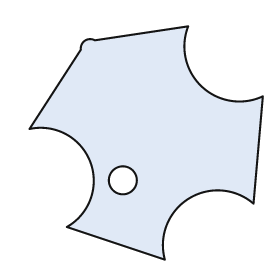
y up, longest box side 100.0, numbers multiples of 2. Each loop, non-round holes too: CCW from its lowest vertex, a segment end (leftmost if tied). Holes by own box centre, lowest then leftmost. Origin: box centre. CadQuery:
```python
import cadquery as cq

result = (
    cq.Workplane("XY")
    .moveTo(8.0, -50.0)
    .threePointArc((18.0, -24.0), (46.0, -26.0))
    .lineTo(50.0, 20.0)
    .threePointArc((24.0, 24.0), (18.0, 50.0))
    .lineTo(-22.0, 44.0)
    .threePointArc((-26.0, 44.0), (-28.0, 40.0))
    .lineTo(-50.0, 6.0)
    .threePointArc((-24.0, -8.0), (-34.0, -36.0))
    .close()
    .moveTo(-10.0, -16.0)
    .circle(6.0)
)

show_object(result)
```